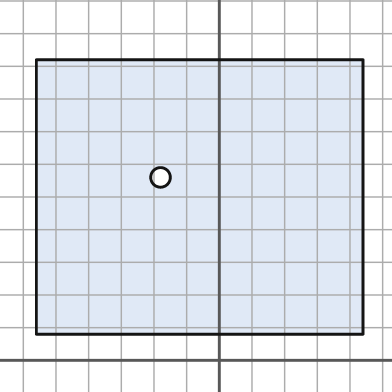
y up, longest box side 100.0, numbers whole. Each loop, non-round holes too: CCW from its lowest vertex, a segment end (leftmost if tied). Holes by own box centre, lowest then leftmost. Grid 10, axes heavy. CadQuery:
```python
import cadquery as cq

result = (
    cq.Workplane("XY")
    .moveTo(-56.0, 8.0)
    .lineTo(44.0, 8.0)
    .lineTo(44.0, 92.0)
    .lineTo(-56.0, 92.0)
    .close()
    .moveTo(-18.0, 56.0)
    .circle(3.0)
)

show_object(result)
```